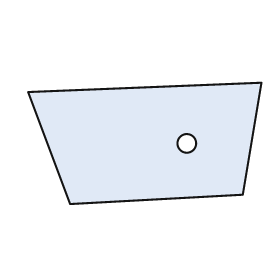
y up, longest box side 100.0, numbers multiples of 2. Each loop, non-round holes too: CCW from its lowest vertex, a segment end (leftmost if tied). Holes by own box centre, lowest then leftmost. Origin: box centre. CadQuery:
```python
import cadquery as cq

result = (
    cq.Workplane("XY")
    .moveTo(-32.0, -26.0)
    .lineTo(42.0, -22.0)
    .lineTo(50.0, 26.0)
    .lineTo(-50.0, 22.0)
    .close()
    .moveTo(18.0, 0.0)
    .circle(4.0)
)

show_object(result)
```